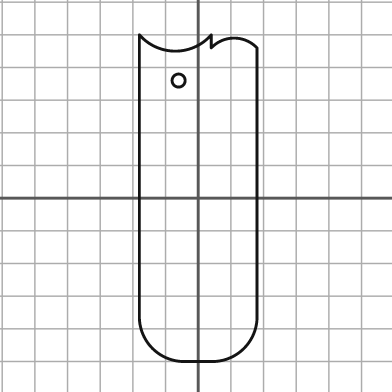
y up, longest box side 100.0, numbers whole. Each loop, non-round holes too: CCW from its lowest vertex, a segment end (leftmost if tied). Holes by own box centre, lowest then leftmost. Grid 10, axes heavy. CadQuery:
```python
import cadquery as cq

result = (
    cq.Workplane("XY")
    .moveTo(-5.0, -50.0)
    .lineTo(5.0, -50.0)
    .threePointArc((14.0, -46.0), (18.0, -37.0))
    .lineTo(18.0, 46.0)
    .threePointArc((11.0, 49.0), (4.0, 46.0))
    .lineTo(4.0, 50.0)
    .threePointArc((-7.0, 45.0), (-18.0, 50.0))
    .lineTo(-18.0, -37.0)
    .threePointArc((-14.0, -46.0), (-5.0, -50.0))
    .close()
    .moveTo(-6.0, 36.0)
    .circle(2.0)
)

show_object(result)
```